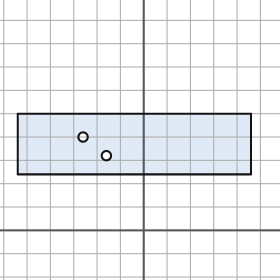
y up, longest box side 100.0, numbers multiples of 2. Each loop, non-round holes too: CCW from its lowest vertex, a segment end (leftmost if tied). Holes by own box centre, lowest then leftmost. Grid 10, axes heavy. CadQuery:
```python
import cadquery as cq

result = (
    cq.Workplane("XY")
    .moveTo(-54.0, 24.0)
    .lineTo(46.0, 24.0)
    .lineTo(46.0, 50.0)
    .lineTo(-54.0, 50.0)
    .close()
    .moveTo(-16.0, 32.0)
    .circle(2.0)
    .moveTo(-26.0, 40.0)
    .circle(2.0)
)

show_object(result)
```